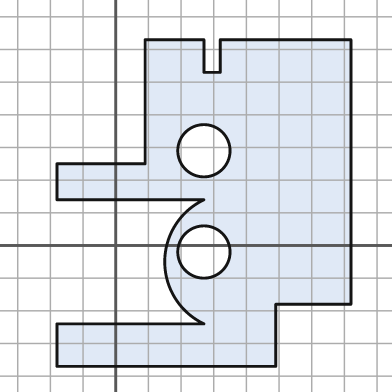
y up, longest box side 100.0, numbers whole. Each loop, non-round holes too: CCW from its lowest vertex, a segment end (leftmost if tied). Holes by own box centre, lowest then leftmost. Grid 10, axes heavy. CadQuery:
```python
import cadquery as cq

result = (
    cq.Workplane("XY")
    .moveTo(-18.0, -37.0)
    .lineTo(49.0, -37.0)
    .lineTo(49.0, -18.0)
    .lineTo(72.0, -18.0)
    .lineTo(72.0, 63.0)
    .lineTo(32.0, 63.0)
    .lineTo(32.0, 53.0)
    .lineTo(27.0, 53.0)
    .lineTo(27.0, 63.0)
    .lineTo(9.0, 63.0)
    .lineTo(9.0, 25.0)
    .lineTo(-18.0, 25.0)
    .lineTo(-18.0, 14.0)
    .lineTo(27.0, 14.0)
    .threePointArc((15.0, -5.0), (27.0, -24.0))
    .lineTo(-18.0, -24.0)
    .close()
    .moveTo(27.0, -2.0)
    .circle(8.0)
    .moveTo(27.0, 29.0)
    .circle(8.0)
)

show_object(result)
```